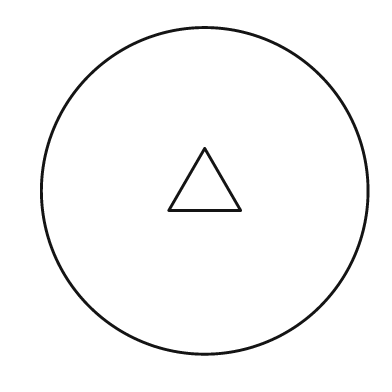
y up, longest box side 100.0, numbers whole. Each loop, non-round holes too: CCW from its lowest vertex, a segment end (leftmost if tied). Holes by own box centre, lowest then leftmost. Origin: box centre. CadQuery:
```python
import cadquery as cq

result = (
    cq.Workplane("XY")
    .moveTo(0.0, 0.0)
    .circle(50.0)
    .moveTo(-11.0, -6.0)
    .lineTo(11.0, -6.0)
    .lineTo(0.0, 13.0)
    .close()
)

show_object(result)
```